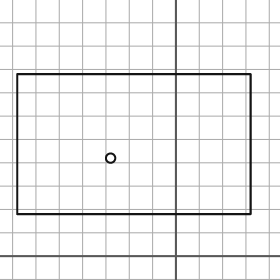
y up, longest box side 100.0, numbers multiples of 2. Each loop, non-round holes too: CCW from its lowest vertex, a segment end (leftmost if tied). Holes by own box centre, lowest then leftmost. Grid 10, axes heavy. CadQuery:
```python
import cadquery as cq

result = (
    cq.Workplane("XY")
    .moveTo(-68.0, 18.0)
    .lineTo(32.0, 18.0)
    .lineTo(32.0, 78.0)
    .lineTo(-68.0, 78.0)
    .close()
    .moveTo(-28.0, 42.0)
    .circle(2.0)
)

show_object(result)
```